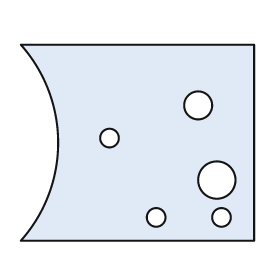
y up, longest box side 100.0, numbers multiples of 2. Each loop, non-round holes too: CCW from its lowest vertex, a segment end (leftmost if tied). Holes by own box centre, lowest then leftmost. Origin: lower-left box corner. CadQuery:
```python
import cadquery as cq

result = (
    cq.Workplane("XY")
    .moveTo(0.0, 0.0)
    .lineTo(100.0, 0.0)
    .lineTo(100.0, 84.0)
    .lineTo(0.0, 84.0)
    .threePointArc((16.0, 42.0), (0.0, 0.0))
    .close()
    .moveTo(58.0, 10.0)
    .circle(4.0)
    .moveTo(86.0, 10.0)
    .circle(4.0)
    .moveTo(84.0, 26.0)
    .circle(8.0)
    .moveTo(38.0, 44.0)
    .circle(4.0)
    .moveTo(76.0, 58.0)
    .circle(6.0)
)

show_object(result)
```